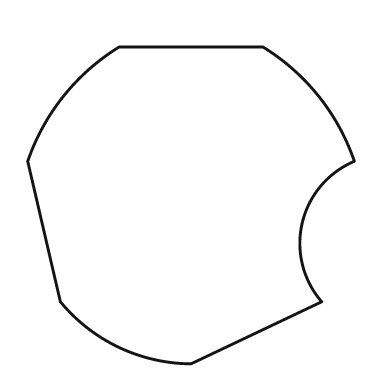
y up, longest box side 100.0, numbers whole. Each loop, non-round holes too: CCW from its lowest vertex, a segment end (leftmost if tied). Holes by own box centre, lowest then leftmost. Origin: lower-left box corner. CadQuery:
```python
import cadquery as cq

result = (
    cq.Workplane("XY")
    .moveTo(50.0, 0.0)
    .lineTo(90.0, 19.0)
    .threePointArc((84.0, 43.0), (100.0, 62.0))
    .threePointArc((89.0, 82.0), (72.0, 97.0))
    .lineTo(28.0, 97.0)
    .threePointArc((11.0, 82.0), (0.0, 62.0))
    .lineTo(10.0, 19.0)
    .threePointArc((28.0, 5.0), (50.0, 0.0))
    .close()
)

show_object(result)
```